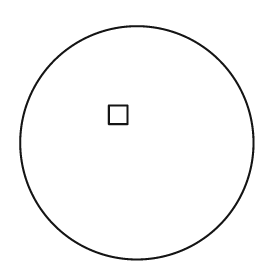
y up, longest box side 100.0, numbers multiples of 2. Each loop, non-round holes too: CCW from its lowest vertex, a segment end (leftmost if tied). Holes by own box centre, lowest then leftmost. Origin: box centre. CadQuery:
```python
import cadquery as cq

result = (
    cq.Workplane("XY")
    .moveTo(0.0, 0.0)
    .circle(50.0)
    .moveTo(-12.0, 8.0)
    .lineTo(-4.0, 8.0)
    .lineTo(-4.0, 16.0)
    .lineTo(-12.0, 16.0)
    .close()
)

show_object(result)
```